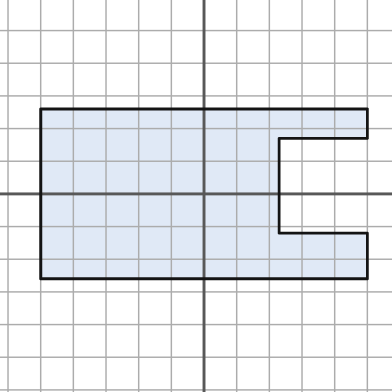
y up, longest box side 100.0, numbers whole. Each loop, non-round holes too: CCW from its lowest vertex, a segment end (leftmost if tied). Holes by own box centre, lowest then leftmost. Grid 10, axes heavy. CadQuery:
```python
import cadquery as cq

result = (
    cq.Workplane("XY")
    .moveTo(-50.0, -26.0)
    .lineTo(50.0, -26.0)
    .lineTo(50.0, -12.0)
    .lineTo(23.0, -12.0)
    .lineTo(23.0, 17.0)
    .lineTo(50.0, 17.0)
    .lineTo(50.0, 26.0)
    .lineTo(-50.0, 26.0)
    .close()
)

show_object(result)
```